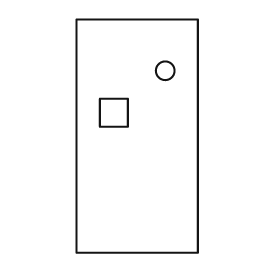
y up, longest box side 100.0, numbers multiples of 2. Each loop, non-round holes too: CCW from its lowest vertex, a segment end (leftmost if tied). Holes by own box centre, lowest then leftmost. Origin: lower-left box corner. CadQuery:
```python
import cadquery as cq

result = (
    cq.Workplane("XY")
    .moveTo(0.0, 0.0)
    .lineTo(52.0, 0.0)
    .lineTo(52.0, 100.0)
    .lineTo(0.0, 100.0)
    .close()
    .moveTo(10.0, 54.0)
    .lineTo(22.0, 54.0)
    .lineTo(22.0, 66.0)
    .lineTo(10.0, 66.0)
    .close()
    .moveTo(38.0, 78.0)
    .circle(4.0)
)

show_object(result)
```